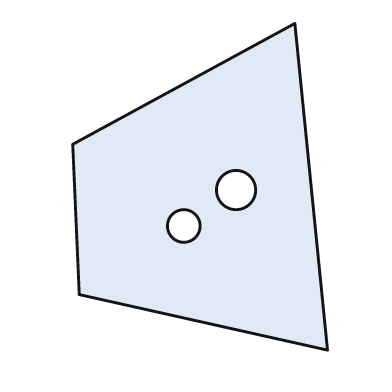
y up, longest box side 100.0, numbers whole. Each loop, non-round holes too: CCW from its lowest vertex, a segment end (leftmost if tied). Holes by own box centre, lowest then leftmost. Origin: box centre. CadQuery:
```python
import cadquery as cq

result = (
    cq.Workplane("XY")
    .moveTo(39.0, -50.0)
    .lineTo(29.0, 50.0)
    .lineTo(-39.0, 13.0)
    .lineTo(-37.0, -33.0)
    .close()
    .moveTo(-5.0, -12.0)
    .circle(5.0)
    .moveTo(11.0, -1.0)
    .circle(6.0)
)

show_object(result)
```